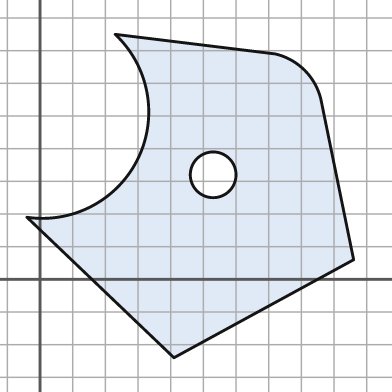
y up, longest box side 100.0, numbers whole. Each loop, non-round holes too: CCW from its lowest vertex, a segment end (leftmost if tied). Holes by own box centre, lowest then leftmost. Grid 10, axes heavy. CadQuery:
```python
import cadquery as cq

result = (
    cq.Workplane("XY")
    .moveTo(41.0, -24.0)
    .lineTo(96.0, 6.0)
    .lineTo(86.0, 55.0)
    .threePointArc((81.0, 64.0), (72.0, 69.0))
    .lineTo(23.0, 75.0)
    .threePointArc((30.0, 37.0), (-4.0, 19.0))
    .close()
    .moveTo(53.0, 32.0)
    .circle(7.0)
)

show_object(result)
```